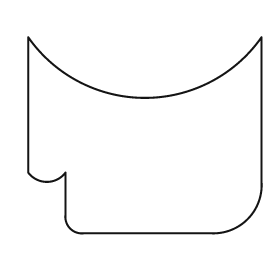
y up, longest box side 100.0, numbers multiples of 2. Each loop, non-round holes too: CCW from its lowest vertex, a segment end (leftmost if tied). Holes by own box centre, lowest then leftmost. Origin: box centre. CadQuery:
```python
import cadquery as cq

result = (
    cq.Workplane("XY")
    .moveTo(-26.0, -42.0)
    .lineTo(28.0, -42.0)
    .threePointArc((44.0, -36.0), (50.0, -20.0))
    .lineTo(50.0, 42.0)
    .threePointArc((0.0, 16.0), (-50.0, 42.0))
    .lineTo(-50.0, -16.0)
    .threePointArc((-42.0, -20.0), (-34.0, -16.0))
    .lineTo(-34.0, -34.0)
    .threePointArc((-32.0, -40.0), (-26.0, -42.0))
    .close()
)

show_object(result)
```